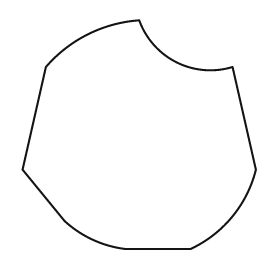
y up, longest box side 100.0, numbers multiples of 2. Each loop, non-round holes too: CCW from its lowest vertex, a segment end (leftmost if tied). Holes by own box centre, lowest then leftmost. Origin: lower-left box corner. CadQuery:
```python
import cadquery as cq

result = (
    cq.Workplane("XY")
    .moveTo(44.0, 0.0)
    .lineTo(72.0, 0.0)
    .threePointArc((90.0, 14.0), (100.0, 34.0))
    .lineTo(90.0, 78.0)
    .threePointArc((66.0, 80.0), (50.0, 98.0))
    .threePointArc((28.0, 92.0), (10.0, 78.0))
    .lineTo(0.0, 34.0)
    .lineTo(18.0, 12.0)
    .threePointArc((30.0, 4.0), (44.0, 0.0))
    .close()
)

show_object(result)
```